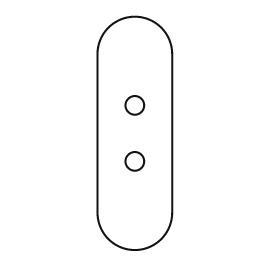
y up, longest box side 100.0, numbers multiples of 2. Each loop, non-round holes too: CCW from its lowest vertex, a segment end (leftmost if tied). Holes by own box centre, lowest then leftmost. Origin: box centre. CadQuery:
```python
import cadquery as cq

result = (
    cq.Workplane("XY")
    .moveTo(-16.0, -34.0)
    .threePointArc((0.0, -50.0), (16.0, -34.0))
    .lineTo(16.0, 34.0)
    .threePointArc((0.0, 50.0), (-16.0, 34.0))
    .close()
    .moveTo(0.0, -12.0)
    .circle(4.0)
    .moveTo(0.0, 12.0)
    .circle(4.0)
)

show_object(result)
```